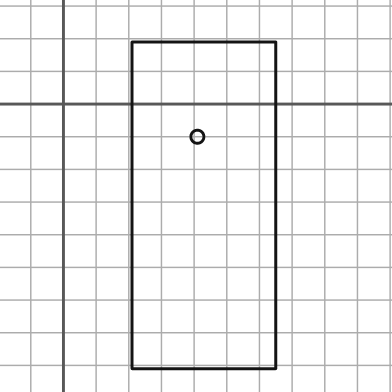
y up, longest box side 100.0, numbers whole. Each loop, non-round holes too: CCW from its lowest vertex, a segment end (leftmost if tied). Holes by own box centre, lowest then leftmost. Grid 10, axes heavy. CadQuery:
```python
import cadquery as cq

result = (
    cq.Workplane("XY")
    .moveTo(21.0, -81.0)
    .lineTo(65.0, -81.0)
    .lineTo(65.0, 19.0)
    .lineTo(21.0, 19.0)
    .close()
    .moveTo(41.0, -10.0)
    .circle(2.0)
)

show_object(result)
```